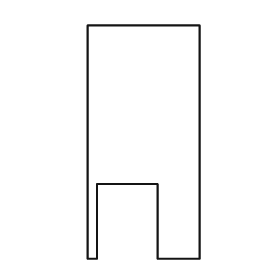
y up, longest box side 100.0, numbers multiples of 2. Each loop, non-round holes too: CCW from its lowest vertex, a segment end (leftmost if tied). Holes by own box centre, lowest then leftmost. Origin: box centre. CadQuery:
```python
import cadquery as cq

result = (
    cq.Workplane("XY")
    .moveTo(-24.0, -50.0)
    .lineTo(-20.0, -50.0)
    .lineTo(-20.0, -18.0)
    .lineTo(6.0, -18.0)
    .lineTo(6.0, -50.0)
    .lineTo(24.0, -50.0)
    .lineTo(24.0, 50.0)
    .lineTo(-24.0, 50.0)
    .close()
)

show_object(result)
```